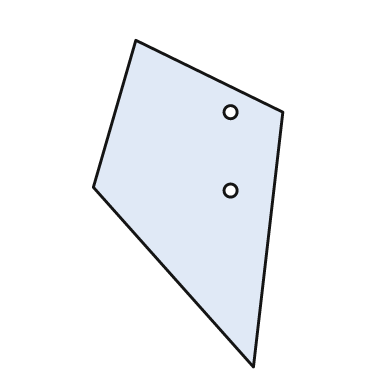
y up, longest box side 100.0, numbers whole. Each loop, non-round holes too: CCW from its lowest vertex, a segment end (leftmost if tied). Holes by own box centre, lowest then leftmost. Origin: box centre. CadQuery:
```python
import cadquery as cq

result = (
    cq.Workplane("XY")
    .moveTo(20.0, -50.0)
    .lineTo(29.0, 28.0)
    .lineTo(-16.0, 50.0)
    .lineTo(-29.0, 5.0)
    .close()
    .moveTo(13.0, 4.0)
    .circle(2.0)
    .moveTo(13.0, 28.0)
    .circle(2.0)
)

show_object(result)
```